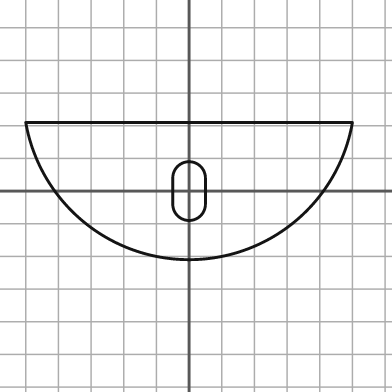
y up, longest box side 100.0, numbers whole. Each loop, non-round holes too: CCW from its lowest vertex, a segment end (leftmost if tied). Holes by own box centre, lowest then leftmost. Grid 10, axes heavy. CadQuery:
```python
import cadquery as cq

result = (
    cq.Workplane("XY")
    .moveTo(-50.0, 21.0)
    .threePointArc((0.0, -21.0), (50.0, 21.0))
    .close()
    .moveTo(-5.0, -4.0)
    .threePointArc((0.0, -9.0), (5.0, -4.0))
    .lineTo(5.0, 4.0)
    .threePointArc((0.0, 9.0), (-5.0, 4.0))
    .close()
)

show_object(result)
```